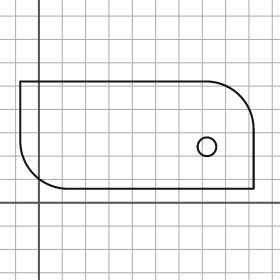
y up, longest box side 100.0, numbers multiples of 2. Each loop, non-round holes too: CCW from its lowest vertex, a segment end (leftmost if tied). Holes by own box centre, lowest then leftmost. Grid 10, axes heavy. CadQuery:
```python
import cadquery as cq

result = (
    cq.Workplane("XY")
    .moveTo(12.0, 6.0)
    .lineTo(92.0, 6.0)
    .lineTo(92.0, 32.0)
    .threePointArc((86.0, 46.0), (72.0, 52.0))
    .lineTo(-8.0, 52.0)
    .lineTo(-8.0, 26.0)
    .threePointArc((-2.0, 12.0), (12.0, 6.0))
    .close()
    .moveTo(72.0, 24.0)
    .circle(4.0)
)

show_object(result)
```